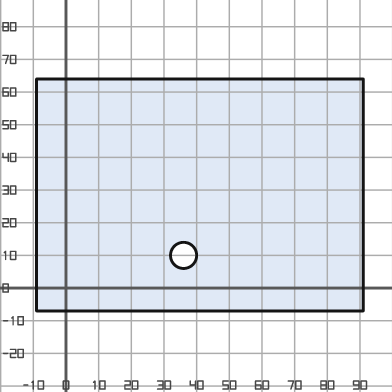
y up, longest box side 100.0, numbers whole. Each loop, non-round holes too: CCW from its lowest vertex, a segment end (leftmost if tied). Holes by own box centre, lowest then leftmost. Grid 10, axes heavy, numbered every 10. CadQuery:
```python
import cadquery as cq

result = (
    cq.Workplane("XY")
    .moveTo(-9.0, -7.0)
    .lineTo(91.0, -7.0)
    .lineTo(91.0, 64.0)
    .lineTo(-9.0, 64.0)
    .close()
    .moveTo(36.0, 10.0)
    .circle(4.0)
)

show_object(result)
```